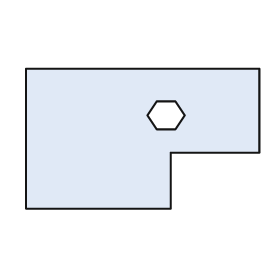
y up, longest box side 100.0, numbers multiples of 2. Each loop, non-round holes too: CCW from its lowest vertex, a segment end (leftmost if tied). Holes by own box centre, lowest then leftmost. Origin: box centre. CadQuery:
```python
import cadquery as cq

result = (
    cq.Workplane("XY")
    .moveTo(-50.0, -30.0)
    .lineTo(12.0, -30.0)
    .lineTo(12.0, -6.0)
    .lineTo(50.0, -6.0)
    .lineTo(50.0, 30.0)
    .lineTo(-50.0, 30.0)
    .close()
    .moveTo(6.0, 4.0)
    .lineTo(14.0, 4.0)
    .lineTo(18.0, 10.0)
    .lineTo(14.0, 16.0)
    .lineTo(6.0, 16.0)
    .lineTo(2.0, 10.0)
    .close()
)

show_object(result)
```